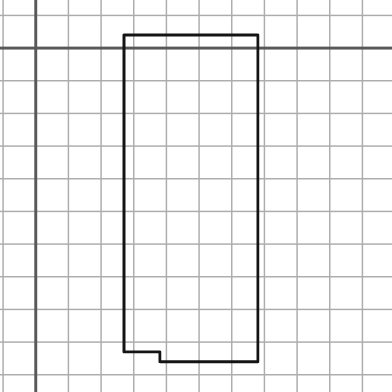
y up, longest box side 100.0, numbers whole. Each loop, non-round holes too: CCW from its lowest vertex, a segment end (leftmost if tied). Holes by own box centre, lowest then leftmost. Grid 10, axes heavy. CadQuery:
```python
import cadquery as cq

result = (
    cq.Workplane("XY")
    .moveTo(38.0, -96.0)
    .lineTo(68.0, -96.0)
    .lineTo(68.0, 4.0)
    .lineTo(27.0, 4.0)
    .lineTo(27.0, -93.0)
    .lineTo(38.0, -93.0)
    .close()
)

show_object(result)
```